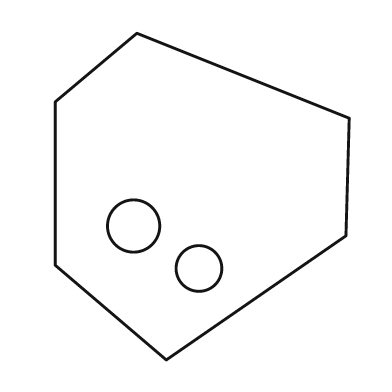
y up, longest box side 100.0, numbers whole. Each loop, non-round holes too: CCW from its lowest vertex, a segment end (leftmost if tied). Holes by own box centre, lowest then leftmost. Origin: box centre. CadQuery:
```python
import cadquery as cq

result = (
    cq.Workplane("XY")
    .moveTo(-11.0, -50.0)
    .lineTo(44.0, -12.0)
    .lineTo(45.0, 24.0)
    .lineTo(-20.0, 50.0)
    .lineTo(-45.0, 29.0)
    .lineTo(-45.0, -21.0)
    .close()
    .moveTo(-1.0, -22.0)
    .circle(7.0)
    .moveTo(-21.0, -9.0)
    .circle(8.0)
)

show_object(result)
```